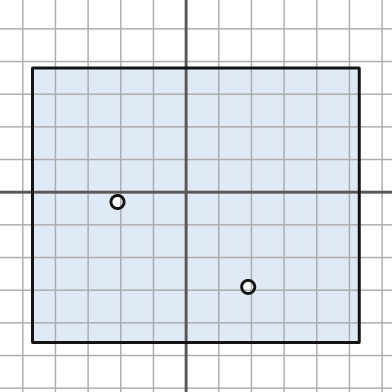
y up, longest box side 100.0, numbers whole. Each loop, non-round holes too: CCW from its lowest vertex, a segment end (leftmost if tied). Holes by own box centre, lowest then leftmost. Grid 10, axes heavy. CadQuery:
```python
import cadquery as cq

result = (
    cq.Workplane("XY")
    .moveTo(-47.0, -46.0)
    .lineTo(53.0, -46.0)
    .lineTo(53.0, 38.0)
    .lineTo(-47.0, 38.0)
    .close()
    .moveTo(19.0, -29.0)
    .circle(2.0)
    .moveTo(-21.0, -3.0)
    .circle(2.0)
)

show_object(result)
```